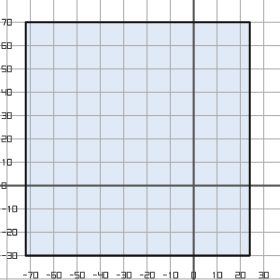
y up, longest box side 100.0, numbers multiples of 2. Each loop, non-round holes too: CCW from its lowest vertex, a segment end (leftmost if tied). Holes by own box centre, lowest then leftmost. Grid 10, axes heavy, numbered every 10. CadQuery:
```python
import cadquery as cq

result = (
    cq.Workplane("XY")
    .moveTo(-72.0, -30.0)
    .lineTo(24.0, -30.0)
    .lineTo(24.0, 70.0)
    .lineTo(-72.0, 70.0)
    .close()
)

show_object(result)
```